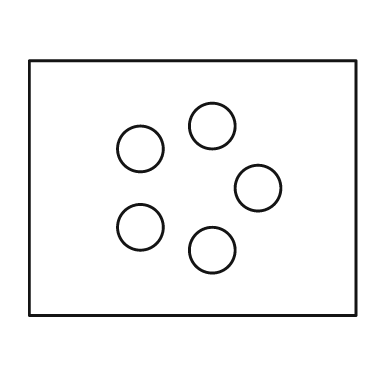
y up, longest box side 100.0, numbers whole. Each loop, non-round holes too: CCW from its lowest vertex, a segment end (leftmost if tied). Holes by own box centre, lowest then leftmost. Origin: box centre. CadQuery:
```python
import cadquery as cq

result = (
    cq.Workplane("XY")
    .moveTo(-50.0, -39.0)
    .lineTo(50.0, -39.0)
    .lineTo(50.0, 39.0)
    .lineTo(-50.0, 39.0)
    .close()
    .moveTo(6.0, -19.0)
    .circle(7.0)
    .moveTo(-16.0, -12.0)
    .circle(7.0)
    .moveTo(20.0, 0.0)
    .circle(7.0)
    .moveTo(-16.0, 12.0)
    .circle(7.0)
    .moveTo(6.0, 19.0)
    .circle(7.0)
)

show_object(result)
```